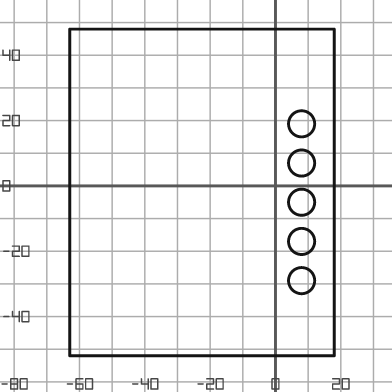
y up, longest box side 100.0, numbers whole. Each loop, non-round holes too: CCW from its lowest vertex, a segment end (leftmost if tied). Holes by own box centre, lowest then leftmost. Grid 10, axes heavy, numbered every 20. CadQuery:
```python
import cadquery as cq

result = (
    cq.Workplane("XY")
    .moveTo(-63.0, -52.0)
    .lineTo(18.0, -52.0)
    .lineTo(18.0, 48.0)
    .lineTo(-63.0, 48.0)
    .close()
    .moveTo(8.0, -29.0)
    .circle(4.0)
    .moveTo(8.0, -17.0)
    .circle(4.0)
    .moveTo(8.0, -5.0)
    .circle(4.0)
    .moveTo(8.0, 7.0)
    .circle(4.0)
    .moveTo(8.0, 19.0)
    .circle(4.0)
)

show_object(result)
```